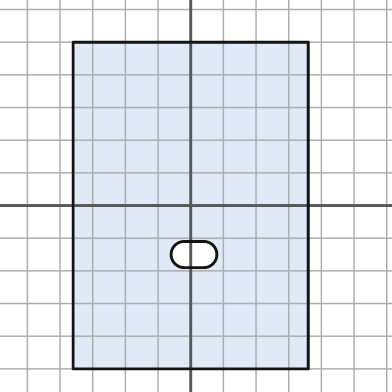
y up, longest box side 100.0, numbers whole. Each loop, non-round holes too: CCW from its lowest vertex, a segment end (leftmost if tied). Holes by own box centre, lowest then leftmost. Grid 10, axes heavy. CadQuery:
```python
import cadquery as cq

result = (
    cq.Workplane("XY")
    .moveTo(-36.0, -50.0)
    .lineTo(36.0, -50.0)
    .lineTo(36.0, 50.0)
    .lineTo(-36.0, 50.0)
    .close()
    .moveTo(-2.0, -19.0)
    .lineTo(4.0, -19.0)
    .threePointArc((8.0, -15.0), (4.0, -11.0))
    .lineTo(-2.0, -11.0)
    .threePointArc((-6.0, -15.0), (-2.0, -19.0))
    .close()
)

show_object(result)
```